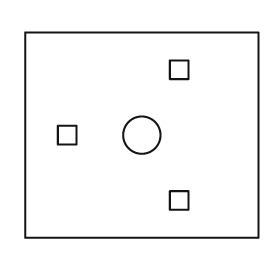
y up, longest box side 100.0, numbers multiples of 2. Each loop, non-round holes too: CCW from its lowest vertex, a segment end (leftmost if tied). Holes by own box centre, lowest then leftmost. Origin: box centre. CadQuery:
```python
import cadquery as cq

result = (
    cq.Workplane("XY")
    .moveTo(-50.0, -44.0)
    .lineTo(50.0, -44.0)
    .lineTo(50.0, 44.0)
    .lineTo(-50.0, 44.0)
    .close()
    .moveTo(12.0, -32.0)
    .lineTo(20.0, -32.0)
    .lineTo(20.0, -24.0)
    .lineTo(12.0, -24.0)
    .close()
    .moveTo(-36.0, -4.0)
    .lineTo(-28.0, -4.0)
    .lineTo(-28.0, 4.0)
    .lineTo(-36.0, 4.0)
    .close()
    .moveTo(0.0, 0.0)
    .circle(8.0)
    .moveTo(12.0, 24.0)
    .lineTo(20.0, 24.0)
    .lineTo(20.0, 32.0)
    .lineTo(12.0, 32.0)
    .close()
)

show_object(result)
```